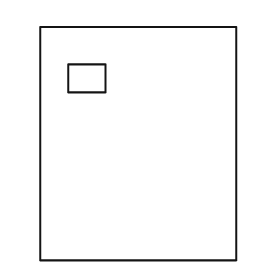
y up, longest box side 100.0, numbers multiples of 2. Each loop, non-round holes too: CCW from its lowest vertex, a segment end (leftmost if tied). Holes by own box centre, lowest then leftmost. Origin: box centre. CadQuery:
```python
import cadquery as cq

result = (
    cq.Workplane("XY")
    .moveTo(-42.0, -50.0)
    .lineTo(42.0, -50.0)
    .lineTo(42.0, 50.0)
    .lineTo(-42.0, 50.0)
    .close()
    .moveTo(-30.0, 22.0)
    .lineTo(-14.0, 22.0)
    .lineTo(-14.0, 34.0)
    .lineTo(-30.0, 34.0)
    .close()
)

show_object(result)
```